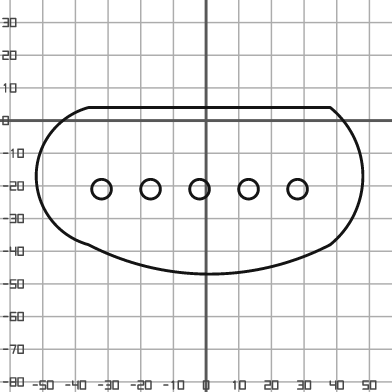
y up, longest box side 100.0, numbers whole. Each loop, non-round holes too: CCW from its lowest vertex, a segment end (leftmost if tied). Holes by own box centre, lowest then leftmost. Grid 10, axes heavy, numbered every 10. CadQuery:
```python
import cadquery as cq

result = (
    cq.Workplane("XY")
    .moveTo(-36.0, -38.0)
    .threePointArc((1.0, -47.0), (38.0, -38.0))
    .threePointArc((48.0, -17.0), (38.0, 4.0))
    .lineTo(-36.0, 4.0)
    .threePointArc((-52.0, -17.0), (-36.0, -38.0))
    .close()
    .moveTo(-32.0, -21.0)
    .circle(3.0)
    .moveTo(-17.0, -21.0)
    .circle(3.0)
    .moveTo(-2.0, -21.0)
    .circle(3.0)
    .moveTo(13.0, -21.0)
    .circle(3.0)
    .moveTo(28.0, -21.0)
    .circle(3.0)
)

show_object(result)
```